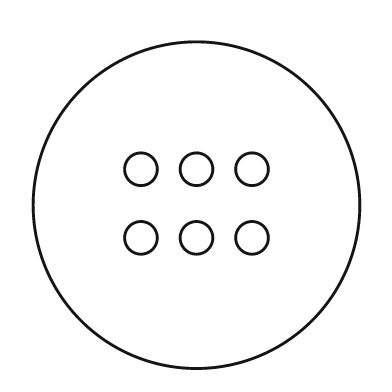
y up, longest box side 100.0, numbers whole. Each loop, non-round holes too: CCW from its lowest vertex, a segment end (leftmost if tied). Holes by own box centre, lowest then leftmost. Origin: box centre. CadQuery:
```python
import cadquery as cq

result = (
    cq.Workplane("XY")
    .moveTo(0.0, 0.0)
    .circle(50.0)
    .moveTo(-17.0, -10.0)
    .circle(5.0)
    .moveTo(0.0, -10.0)
    .circle(5.0)
    .moveTo(17.0, -10.0)
    .circle(5.0)
    .moveTo(-17.0, 11.0)
    .circle(5.0)
    .moveTo(0.0, 11.0)
    .circle(5.0)
    .moveTo(17.0, 11.0)
    .circle(5.0)
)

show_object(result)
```